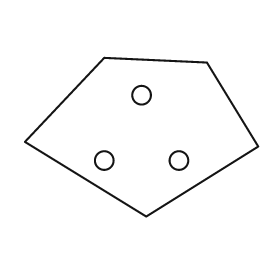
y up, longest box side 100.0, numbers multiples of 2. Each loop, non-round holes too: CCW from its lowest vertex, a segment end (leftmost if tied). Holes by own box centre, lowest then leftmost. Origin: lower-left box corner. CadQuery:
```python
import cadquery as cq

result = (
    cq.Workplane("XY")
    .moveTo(52.0, 0.0)
    .lineTo(100.0, 30.0)
    .lineTo(78.0, 66.0)
    .lineTo(34.0, 68.0)
    .lineTo(0.0, 32.0)
    .close()
    .moveTo(34.0, 24.0)
    .circle(4.0)
    .moveTo(66.0, 24.0)
    .circle(4.0)
    .moveTo(50.0, 52.0)
    .circle(4.0)
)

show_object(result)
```